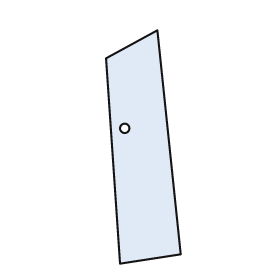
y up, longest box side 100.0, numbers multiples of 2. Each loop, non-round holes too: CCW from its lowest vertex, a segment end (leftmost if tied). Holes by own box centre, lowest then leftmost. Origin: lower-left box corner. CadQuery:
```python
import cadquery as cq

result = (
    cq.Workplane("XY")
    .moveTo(6.0, 0.0)
    .lineTo(32.0, 4.0)
    .lineTo(22.0, 100.0)
    .lineTo(0.0, 88.0)
    .close()
    .moveTo(8.0, 58.0)
    .circle(2.0)
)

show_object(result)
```